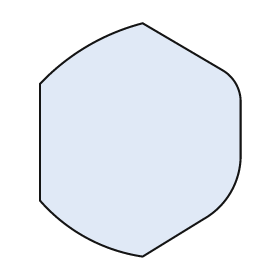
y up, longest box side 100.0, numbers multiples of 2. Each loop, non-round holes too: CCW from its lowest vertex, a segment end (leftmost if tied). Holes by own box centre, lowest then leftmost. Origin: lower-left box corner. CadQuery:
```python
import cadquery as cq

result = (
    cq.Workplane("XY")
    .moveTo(44.0, 0.0)
    .lineTo(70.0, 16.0)
    .threePointArc((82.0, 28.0), (86.0, 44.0))
    .lineTo(86.0, 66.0)
    .threePointArc((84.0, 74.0), (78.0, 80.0))
    .lineTo(44.0, 100.0)
    .threePointArc((20.0, 90.0), (0.0, 74.0))
    .lineTo(0.0, 24.0)
    .threePointArc((20.0, 8.0), (44.0, 0.0))
    .close()
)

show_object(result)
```